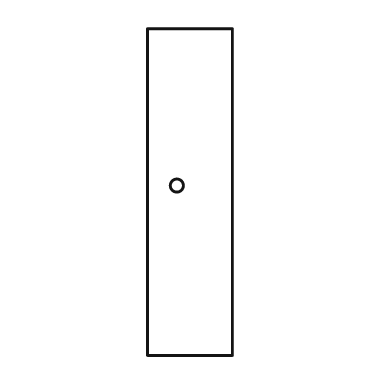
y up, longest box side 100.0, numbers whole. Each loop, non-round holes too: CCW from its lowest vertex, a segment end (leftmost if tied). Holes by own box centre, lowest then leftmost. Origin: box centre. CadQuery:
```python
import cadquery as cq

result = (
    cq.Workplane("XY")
    .moveTo(-13.0, -50.0)
    .lineTo(13.0, -50.0)
    .lineTo(13.0, 50.0)
    .lineTo(-13.0, 50.0)
    .close()
    .moveTo(-4.0, 2.0)
    .circle(2.0)
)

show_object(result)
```